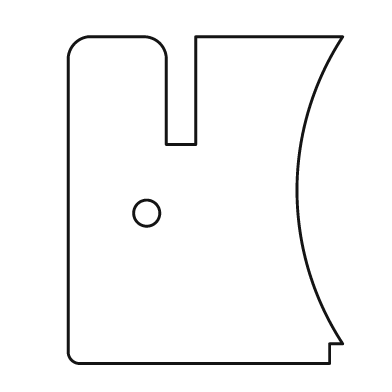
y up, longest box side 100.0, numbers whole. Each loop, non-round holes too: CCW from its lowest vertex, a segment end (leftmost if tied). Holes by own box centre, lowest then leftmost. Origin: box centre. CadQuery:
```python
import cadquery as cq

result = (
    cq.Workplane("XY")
    .moveTo(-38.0, -50.0)
    .lineTo(38.0, -50.0)
    .lineTo(38.0, -44.0)
    .lineTo(42.0, -44.0)
    .threePointArc((28.0, 3.0), (42.0, 50.0))
    .lineTo(-3.0, 50.0)
    .lineTo(-3.0, 17.0)
    .lineTo(-12.0, 17.0)
    .lineTo(-12.0, 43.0)
    .threePointArc((-14.0, 48.0), (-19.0, 50.0))
    .lineTo(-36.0, 50.0)
    .threePointArc((-40.0, 48.0), (-42.0, 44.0))
    .lineTo(-42.0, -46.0)
    .threePointArc((-41.0, -49.0), (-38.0, -50.0))
    .close()
    .moveTo(-18.0, -4.0)
    .circle(4.0)
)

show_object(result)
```